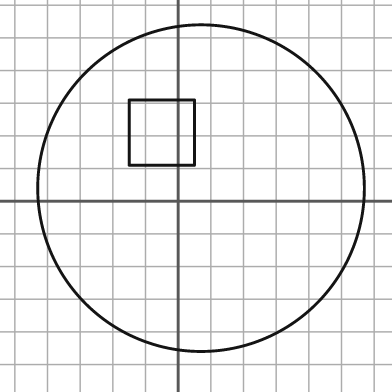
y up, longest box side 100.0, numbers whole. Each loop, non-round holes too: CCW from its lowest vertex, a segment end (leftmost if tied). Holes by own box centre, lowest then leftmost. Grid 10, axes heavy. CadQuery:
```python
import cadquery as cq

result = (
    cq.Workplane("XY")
    .moveTo(7.0, 4.0)
    .circle(50.0)
    .moveTo(-15.0, 11.0)
    .lineTo(5.0, 11.0)
    .lineTo(5.0, 31.0)
    .lineTo(-15.0, 31.0)
    .close()
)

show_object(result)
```